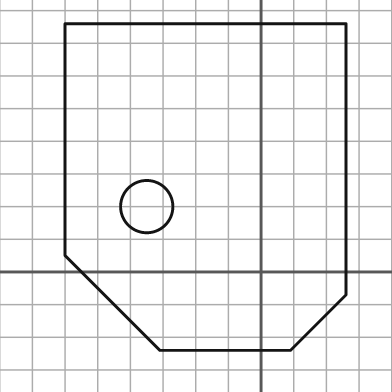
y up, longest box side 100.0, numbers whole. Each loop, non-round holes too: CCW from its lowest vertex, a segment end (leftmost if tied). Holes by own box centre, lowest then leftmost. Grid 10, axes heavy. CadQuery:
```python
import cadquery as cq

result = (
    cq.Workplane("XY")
    .moveTo(-31.0, -24.0)
    .lineTo(9.0, -24.0)
    .lineTo(26.0, -7.0)
    .lineTo(26.0, 76.0)
    .lineTo(-60.0, 76.0)
    .lineTo(-60.0, 5.0)
    .close()
    .moveTo(-35.0, 20.0)
    .circle(8.0)
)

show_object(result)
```